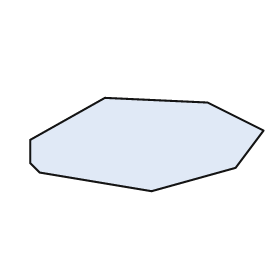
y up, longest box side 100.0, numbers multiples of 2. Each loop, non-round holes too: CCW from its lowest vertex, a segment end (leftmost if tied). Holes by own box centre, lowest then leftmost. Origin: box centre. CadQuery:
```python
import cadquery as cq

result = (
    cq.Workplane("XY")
    .moveTo(2.0, -20.0)
    .lineTo(38.0, -10.0)
    .lineTo(50.0, 6.0)
    .lineTo(26.0, 18.0)
    .lineTo(-18.0, 20.0)
    .lineTo(-50.0, 2.0)
    .lineTo(-50.0, -8.0)
    .lineTo(-46.0, -12.0)
    .close()
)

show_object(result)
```